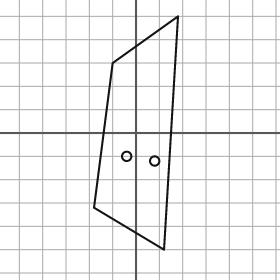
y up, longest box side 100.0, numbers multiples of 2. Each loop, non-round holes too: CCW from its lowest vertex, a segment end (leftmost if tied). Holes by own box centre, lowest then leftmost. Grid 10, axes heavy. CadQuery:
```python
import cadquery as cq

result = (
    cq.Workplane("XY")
    .moveTo(12.0, -50.0)
    .lineTo(18.0, 50.0)
    .lineTo(-10.0, 30.0)
    .lineTo(-18.0, -32.0)
    .close()
    .moveTo(8.0, -12.0)
    .circle(2.0)
    .moveTo(-4.0, -10.0)
    .circle(2.0)
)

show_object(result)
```